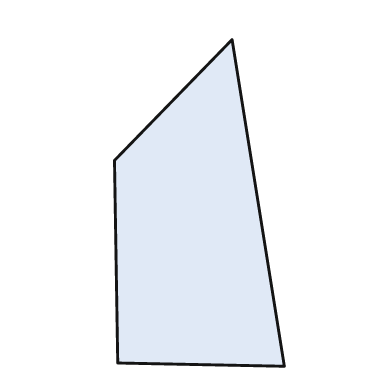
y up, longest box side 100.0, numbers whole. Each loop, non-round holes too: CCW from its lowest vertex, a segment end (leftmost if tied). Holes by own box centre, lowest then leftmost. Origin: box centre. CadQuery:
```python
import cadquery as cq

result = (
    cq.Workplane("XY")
    .moveTo(26.0, -50.0)
    .lineTo(10.0, 50.0)
    .lineTo(-26.0, 13.0)
    .lineTo(-25.0, -49.0)
    .close()
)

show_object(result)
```